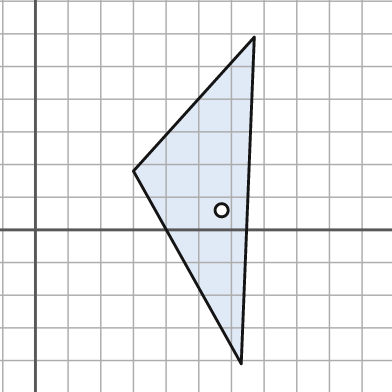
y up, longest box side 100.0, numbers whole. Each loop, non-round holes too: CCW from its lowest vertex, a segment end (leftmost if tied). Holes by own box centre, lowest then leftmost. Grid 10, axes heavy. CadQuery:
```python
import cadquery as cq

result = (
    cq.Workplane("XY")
    .moveTo(63.0, -41.0)
    .lineTo(67.0, 59.0)
    .lineTo(30.0, 18.0)
    .close()
    .moveTo(57.0, 6.0)
    .circle(2.0)
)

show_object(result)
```